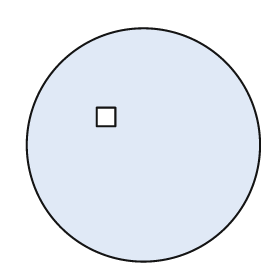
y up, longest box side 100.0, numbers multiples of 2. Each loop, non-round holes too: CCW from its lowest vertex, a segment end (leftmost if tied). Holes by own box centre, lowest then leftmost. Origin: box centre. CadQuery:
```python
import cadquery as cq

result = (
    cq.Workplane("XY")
    .moveTo(0.0, 0.0)
    .circle(50.0)
    .moveTo(-20.0, 8.0)
    .lineTo(-12.0, 8.0)
    .lineTo(-12.0, 16.0)
    .lineTo(-20.0, 16.0)
    .close()
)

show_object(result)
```